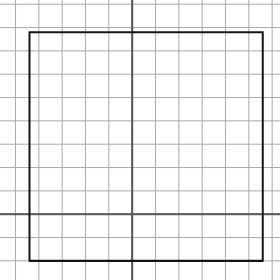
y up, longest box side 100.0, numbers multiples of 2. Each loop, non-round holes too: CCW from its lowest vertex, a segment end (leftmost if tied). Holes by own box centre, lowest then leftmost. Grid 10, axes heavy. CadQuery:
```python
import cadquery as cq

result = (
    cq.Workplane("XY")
    .moveTo(-44.0, -20.0)
    .lineTo(56.0, -20.0)
    .lineTo(56.0, 78.0)
    .lineTo(-44.0, 78.0)
    .close()
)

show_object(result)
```